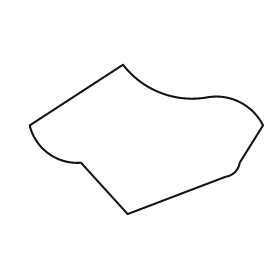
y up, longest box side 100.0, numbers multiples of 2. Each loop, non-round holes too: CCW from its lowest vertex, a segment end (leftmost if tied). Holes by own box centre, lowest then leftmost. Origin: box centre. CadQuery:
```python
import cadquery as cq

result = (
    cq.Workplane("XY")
    .moveTo(-8.0, -32.0)
    .lineTo(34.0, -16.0)
    .threePointArc((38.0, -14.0), (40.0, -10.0))
    .lineTo(50.0, 6.0)
    .threePointArc((40.0, 16.0), (26.0, 18.0))
    .threePointArc((6.0, 20.0), (-10.0, 32.0))
    .lineTo(-50.0, 6.0)
    .threePointArc((-42.0, -6.0), (-28.0, -10.0))
    .close()
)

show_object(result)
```